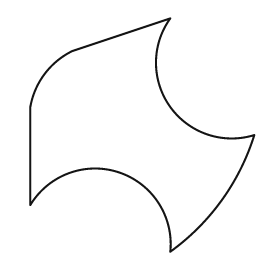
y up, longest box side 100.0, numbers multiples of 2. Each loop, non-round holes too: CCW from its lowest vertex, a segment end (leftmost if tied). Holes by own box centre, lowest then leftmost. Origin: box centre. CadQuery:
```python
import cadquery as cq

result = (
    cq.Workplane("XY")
    .moveTo(12.0, -50.0)
    .threePointArc((34.0, -28.0), (48.0, 0.0))
    .threePointArc((12.0, 12.0), (12.0, 50.0))
    .lineTo(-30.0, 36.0)
    .threePointArc((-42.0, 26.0), (-48.0, 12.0))
    .lineTo(-48.0, -30.0)
    .threePointArc((-10.0, -16.0), (12.0, -50.0))
    .close()
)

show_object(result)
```